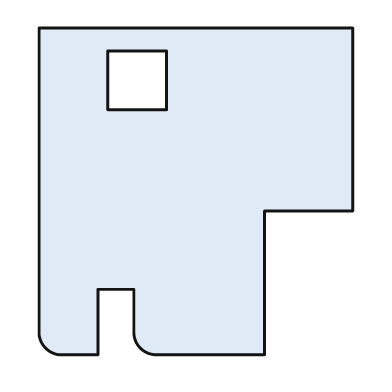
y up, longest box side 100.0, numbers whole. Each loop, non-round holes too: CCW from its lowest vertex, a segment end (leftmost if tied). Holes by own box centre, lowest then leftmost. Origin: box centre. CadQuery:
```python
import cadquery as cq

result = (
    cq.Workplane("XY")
    .moveTo(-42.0, -50.0)
    .lineTo(-30.0, -50.0)
    .lineTo(-30.0, -30.0)
    .lineTo(-19.0, -30.0)
    .lineTo(-19.0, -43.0)
    .threePointArc((-17.0, -48.0), (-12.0, -50.0))
    .lineTo(21.0, -50.0)
    .lineTo(21.0, -6.0)
    .lineTo(48.0, -6.0)
    .lineTo(48.0, 50.0)
    .lineTo(-48.0, 50.0)
    .lineTo(-48.0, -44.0)
    .threePointArc((-46.0, -48.0), (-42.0, -50.0))
    .close()
    .moveTo(-27.0, 25.0)
    .lineTo(-9.0, 25.0)
    .lineTo(-9.0, 43.0)
    .lineTo(-27.0, 43.0)
    .close()
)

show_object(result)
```